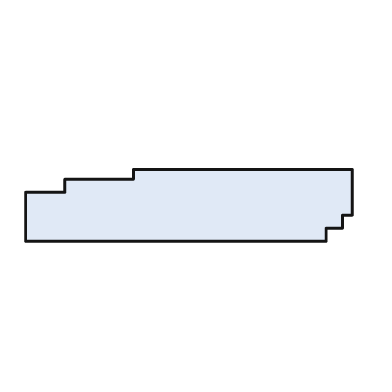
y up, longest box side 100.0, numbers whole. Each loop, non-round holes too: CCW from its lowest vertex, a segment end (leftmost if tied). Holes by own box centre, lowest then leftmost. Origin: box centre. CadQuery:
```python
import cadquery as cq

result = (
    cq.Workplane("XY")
    .moveTo(-50.0, -11.0)
    .lineTo(42.0, -11.0)
    .lineTo(42.0, -7.0)
    .lineTo(47.0, -7.0)
    .lineTo(47.0, -3.0)
    .lineTo(50.0, -3.0)
    .lineTo(50.0, 11.0)
    .lineTo(-17.0, 11.0)
    .lineTo(-17.0, 8.0)
    .lineTo(-38.0, 8.0)
    .lineTo(-38.0, 4.0)
    .lineTo(-50.0, 4.0)
    .close()
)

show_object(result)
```